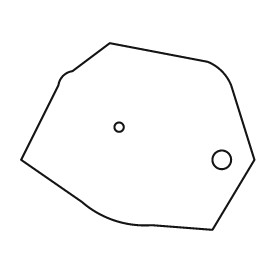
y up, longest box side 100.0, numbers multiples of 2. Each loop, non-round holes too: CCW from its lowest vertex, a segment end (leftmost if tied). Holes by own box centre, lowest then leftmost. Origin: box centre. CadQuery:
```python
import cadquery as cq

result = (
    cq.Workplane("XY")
    .moveTo(32.0, -40.0)
    .lineTo(50.0, -10.0)
    .lineTo(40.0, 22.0)
    .threePointArc((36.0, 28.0), (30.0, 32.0))
    .lineTo(-12.0, 40.0)
    .lineTo(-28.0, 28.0)
    .threePointArc((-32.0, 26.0), (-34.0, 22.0))
    .lineTo(-50.0, -10.0)
    .lineTo(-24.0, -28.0)
    .threePointArc((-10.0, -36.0), (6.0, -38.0))
    .close()
    .moveTo(36.0, -10.0)
    .circle(4.0)
    .moveTo(-8.0, 4.0)
    .circle(2.0)
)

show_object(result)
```